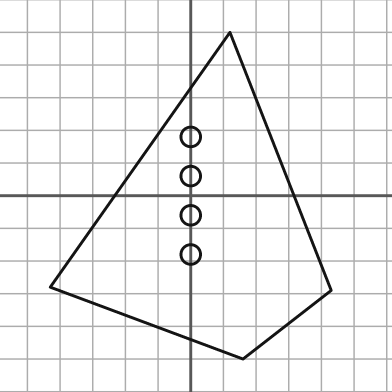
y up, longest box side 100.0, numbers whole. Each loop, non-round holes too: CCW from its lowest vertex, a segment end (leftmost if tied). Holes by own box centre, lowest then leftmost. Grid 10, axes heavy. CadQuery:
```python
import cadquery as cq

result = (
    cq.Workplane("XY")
    .moveTo(16.0, -50.0)
    .lineTo(43.0, -29.0)
    .lineTo(12.0, 50.0)
    .lineTo(-43.0, -28.0)
    .close()
    .moveTo(0.0, -18.0)
    .circle(3.0)
    .moveTo(0.0, -6.0)
    .circle(3.0)
    .moveTo(0.0, 6.0)
    .circle(3.0)
    .moveTo(0.0, 18.0)
    .circle(3.0)
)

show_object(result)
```